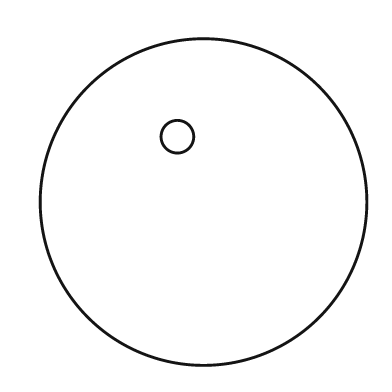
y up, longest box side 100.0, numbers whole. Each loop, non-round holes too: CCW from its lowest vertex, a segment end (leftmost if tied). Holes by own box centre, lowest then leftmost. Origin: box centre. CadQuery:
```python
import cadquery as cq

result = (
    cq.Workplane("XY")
    .moveTo(0.0, 0.0)
    .circle(50.0)
    .moveTo(-8.0, 20.0)
    .circle(5.0)
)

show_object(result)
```